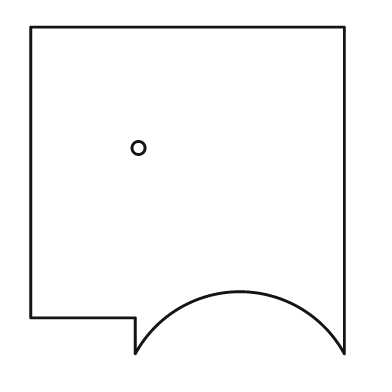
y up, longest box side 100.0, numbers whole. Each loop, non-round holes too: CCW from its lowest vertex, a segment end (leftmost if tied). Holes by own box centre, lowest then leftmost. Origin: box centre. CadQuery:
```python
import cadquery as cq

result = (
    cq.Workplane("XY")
    .moveTo(-16.0, -50.0)
    .threePointArc((16.0, -31.0), (48.0, -50.0))
    .lineTo(48.0, 50.0)
    .lineTo(-48.0, 50.0)
    .lineTo(-48.0, -39.0)
    .lineTo(-16.0, -39.0)
    .close()
    .moveTo(-15.0, 13.0)
    .circle(2.0)
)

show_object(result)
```